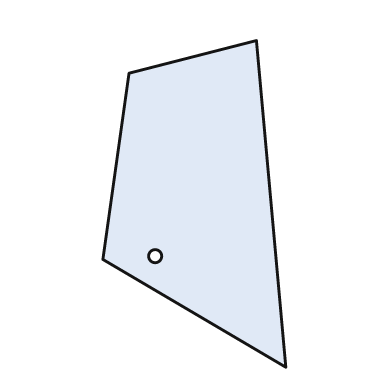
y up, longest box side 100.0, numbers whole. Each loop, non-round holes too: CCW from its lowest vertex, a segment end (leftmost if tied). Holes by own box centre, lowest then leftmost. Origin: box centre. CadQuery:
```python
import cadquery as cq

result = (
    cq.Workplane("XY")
    .moveTo(28.0, -50.0)
    .lineTo(19.0, 50.0)
    .lineTo(-20.0, 40.0)
    .lineTo(-28.0, -17.0)
    .close()
    .moveTo(-12.0, -16.0)
    .circle(2.0)
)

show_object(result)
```